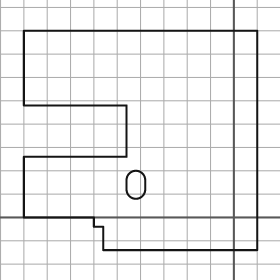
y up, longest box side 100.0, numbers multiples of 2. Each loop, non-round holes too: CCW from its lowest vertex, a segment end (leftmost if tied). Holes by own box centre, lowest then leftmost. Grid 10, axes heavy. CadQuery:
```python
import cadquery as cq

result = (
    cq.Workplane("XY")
    .moveTo(-56.0, -14.0)
    .lineTo(10.0, -14.0)
    .lineTo(10.0, 80.0)
    .lineTo(-90.0, 80.0)
    .lineTo(-90.0, 48.0)
    .lineTo(-46.0, 48.0)
    .lineTo(-46.0, 26.0)
    .lineTo(-90.0, 26.0)
    .lineTo(-90.0, 0.0)
    .lineTo(-60.0, 0.0)
    .lineTo(-60.0, -4.0)
    .lineTo(-56.0, -4.0)
    .close()
    .moveTo(-46.0, 12.0)
    .threePointArc((-42.0, 8.0), (-38.0, 12.0))
    .lineTo(-38.0, 16.0)
    .threePointArc((-42.0, 20.0), (-46.0, 16.0))
    .close()
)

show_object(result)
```